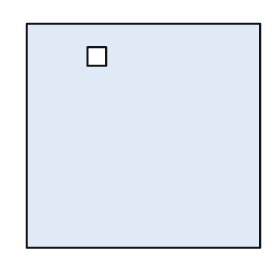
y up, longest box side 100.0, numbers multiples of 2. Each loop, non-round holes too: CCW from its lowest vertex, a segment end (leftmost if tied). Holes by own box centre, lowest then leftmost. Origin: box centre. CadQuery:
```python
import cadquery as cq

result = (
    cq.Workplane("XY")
    .moveTo(-50.0, -48.0)
    .lineTo(50.0, -48.0)
    .lineTo(50.0, 48.0)
    .lineTo(-50.0, 48.0)
    .close()
    .moveTo(-24.0, 30.0)
    .lineTo(-16.0, 30.0)
    .lineTo(-16.0, 38.0)
    .lineTo(-24.0, 38.0)
    .close()
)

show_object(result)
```